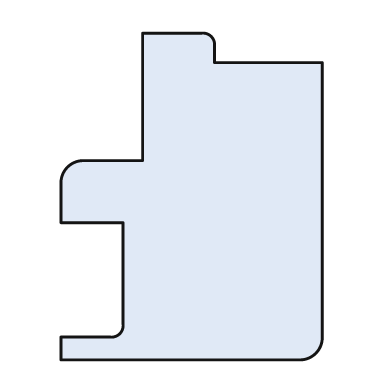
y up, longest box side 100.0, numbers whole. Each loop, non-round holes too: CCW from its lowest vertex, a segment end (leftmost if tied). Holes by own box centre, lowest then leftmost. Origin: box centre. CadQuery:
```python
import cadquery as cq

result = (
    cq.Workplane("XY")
    .moveTo(-40.0, -50.0)
    .lineTo(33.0, -50.0)
    .threePointArc((38.0, -48.0), (40.0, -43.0))
    .lineTo(40.0, 41.0)
    .lineTo(7.0, 41.0)
    .lineTo(7.0, 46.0)
    .threePointArc((6.0, 49.0), (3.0, 50.0))
    .lineTo(-15.0, 50.0)
    .lineTo(-15.0, 11.0)
    .lineTo(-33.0, 11.0)
    .threePointArc((-38.0, 9.0), (-40.0, 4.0))
    .lineTo(-40.0, -8.0)
    .lineTo(-21.0, -8.0)
    .lineTo(-21.0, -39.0)
    .threePointArc((-22.0, -42.0), (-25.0, -43.0))
    .lineTo(-40.0, -43.0)
    .close()
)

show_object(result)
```